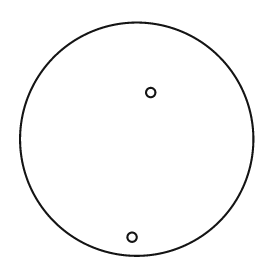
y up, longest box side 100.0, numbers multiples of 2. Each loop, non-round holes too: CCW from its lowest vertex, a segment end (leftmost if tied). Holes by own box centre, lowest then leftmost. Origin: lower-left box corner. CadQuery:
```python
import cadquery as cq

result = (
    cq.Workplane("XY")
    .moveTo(50.0, 50.0)
    .circle(50.0)
    .moveTo(48.0, 8.0)
    .circle(2.0)
    .moveTo(56.0, 70.0)
    .circle(2.0)
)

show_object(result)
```